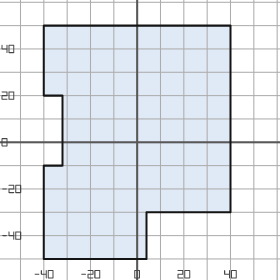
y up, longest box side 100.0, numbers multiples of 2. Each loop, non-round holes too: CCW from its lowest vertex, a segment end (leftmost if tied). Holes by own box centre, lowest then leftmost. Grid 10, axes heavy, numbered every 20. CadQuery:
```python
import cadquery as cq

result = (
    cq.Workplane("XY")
    .moveTo(-40.0, -50.0)
    .lineTo(4.0, -50.0)
    .lineTo(4.0, -30.0)
    .lineTo(40.0, -30.0)
    .lineTo(40.0, 50.0)
    .lineTo(-40.0, 50.0)
    .lineTo(-40.0, 20.0)
    .lineTo(-32.0, 20.0)
    .lineTo(-32.0, -10.0)
    .lineTo(-40.0, -10.0)
    .close()
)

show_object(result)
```